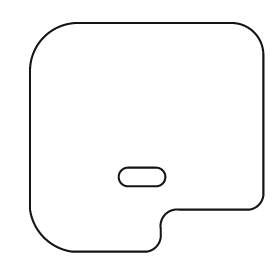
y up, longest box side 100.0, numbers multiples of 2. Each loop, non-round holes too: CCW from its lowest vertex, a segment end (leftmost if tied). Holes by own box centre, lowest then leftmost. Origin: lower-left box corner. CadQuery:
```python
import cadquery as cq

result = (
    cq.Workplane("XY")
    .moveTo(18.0, 0.0)
    .lineTo(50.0, 0.0)
    .threePointArc((54.0, 2.0), (56.0, 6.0))
    .lineTo(56.0, 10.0)
    .threePointArc((58.0, 16.0), (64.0, 18.0))
    .lineTo(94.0, 18.0)
    .threePointArc((98.0, 20.0), (100.0, 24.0))
    .lineTo(100.0, 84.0)
    .threePointArc((96.0, 94.0), (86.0, 98.0))
    .lineTo(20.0, 98.0)
    .threePointArc((6.0, 92.0), (0.0, 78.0))
    .lineTo(0.0, 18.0)
    .threePointArc((6.0, 6.0), (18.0, 0.0))
    .close()
    .moveTo(42.0, 28.0)
    .lineTo(54.0, 28.0)
    .threePointArc((58.0, 32.0), (54.0, 36.0))
    .lineTo(42.0, 36.0)
    .threePointArc((38.0, 32.0), (42.0, 28.0))
    .close()
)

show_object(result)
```